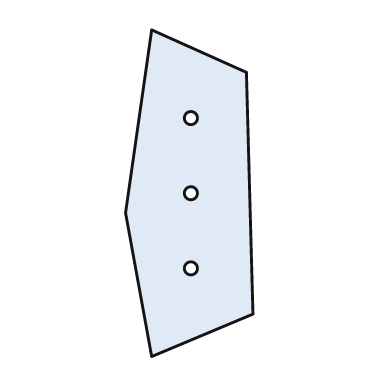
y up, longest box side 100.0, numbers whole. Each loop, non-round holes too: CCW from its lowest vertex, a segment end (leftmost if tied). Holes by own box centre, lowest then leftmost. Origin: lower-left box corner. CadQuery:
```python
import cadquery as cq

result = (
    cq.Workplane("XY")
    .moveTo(8.0, 0.0)
    .lineTo(39.0, 13.0)
    .lineTo(37.0, 87.0)
    .lineTo(8.0, 100.0)
    .lineTo(0.0, 44.0)
    .close()
    .moveTo(20.0, 27.0)
    .circle(2.0)
    .moveTo(20.0, 50.0)
    .circle(2.0)
    .moveTo(20.0, 73.0)
    .circle(2.0)
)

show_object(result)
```